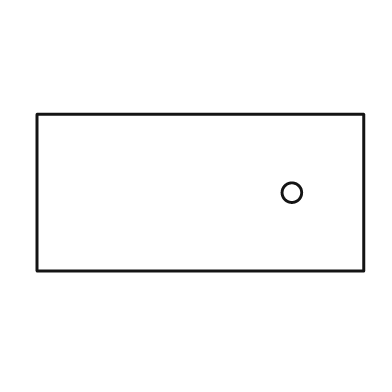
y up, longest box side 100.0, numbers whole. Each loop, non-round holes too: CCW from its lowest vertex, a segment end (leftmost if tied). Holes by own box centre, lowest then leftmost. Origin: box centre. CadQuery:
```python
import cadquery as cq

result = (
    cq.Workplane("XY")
    .moveTo(-50.0, -24.0)
    .lineTo(50.0, -24.0)
    .lineTo(50.0, 24.0)
    .lineTo(-50.0, 24.0)
    .close()
    .moveTo(28.0, 0.0)
    .circle(3.0)
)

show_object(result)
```